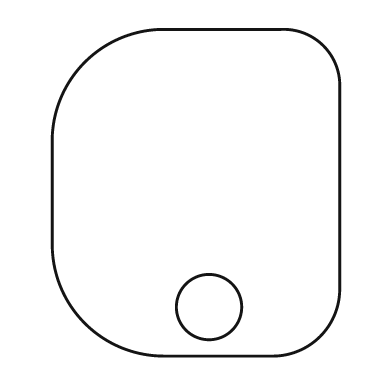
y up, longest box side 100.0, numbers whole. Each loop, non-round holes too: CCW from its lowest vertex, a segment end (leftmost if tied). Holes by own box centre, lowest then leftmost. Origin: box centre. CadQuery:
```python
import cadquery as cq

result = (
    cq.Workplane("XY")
    .moveTo(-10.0, -50.0)
    .lineTo(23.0, -50.0)
    .threePointArc((38.0, -44.0), (44.0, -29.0))
    .lineTo(44.0, 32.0)
    .threePointArc((39.0, 45.0), (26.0, 50.0))
    .lineTo(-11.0, 50.0)
    .threePointArc((-34.0, 40.0), (-44.0, 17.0))
    .lineTo(-44.0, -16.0)
    .threePointArc((-34.0, -40.0), (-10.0, -50.0))
    .close()
    .moveTo(4.0, -35.0)
    .circle(10.0)
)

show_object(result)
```